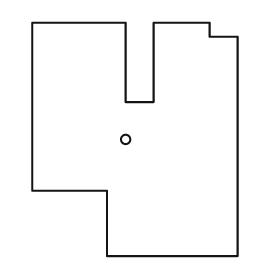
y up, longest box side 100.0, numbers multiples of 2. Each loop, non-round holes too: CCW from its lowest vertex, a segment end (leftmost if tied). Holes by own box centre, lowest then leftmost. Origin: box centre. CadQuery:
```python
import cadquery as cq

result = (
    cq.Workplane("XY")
    .moveTo(-12.0, -50.0)
    .lineTo(44.0, -50.0)
    .lineTo(44.0, 44.0)
    .lineTo(32.0, 44.0)
    .lineTo(32.0, 50.0)
    .lineTo(8.0, 50.0)
    .lineTo(8.0, 16.0)
    .lineTo(-4.0, 16.0)
    .lineTo(-4.0, 50.0)
    .lineTo(-44.0, 50.0)
    .lineTo(-44.0, -22.0)
    .lineTo(-12.0, -22.0)
    .close()
    .moveTo(-4.0, 0.0)
    .circle(2.0)
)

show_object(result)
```